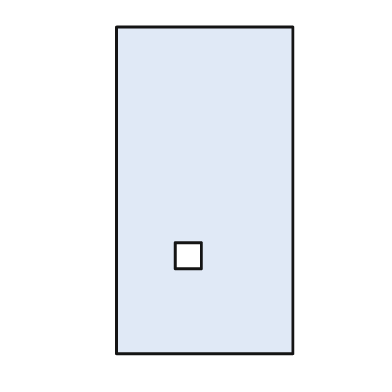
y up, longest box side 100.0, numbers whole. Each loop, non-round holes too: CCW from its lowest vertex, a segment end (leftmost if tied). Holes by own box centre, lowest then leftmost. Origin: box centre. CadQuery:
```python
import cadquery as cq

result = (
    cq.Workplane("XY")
    .moveTo(-27.0, -50.0)
    .lineTo(27.0, -50.0)
    .lineTo(27.0, 50.0)
    .lineTo(-27.0, 50.0)
    .close()
    .moveTo(-9.0, -24.0)
    .lineTo(-1.0, -24.0)
    .lineTo(-1.0, -16.0)
    .lineTo(-9.0, -16.0)
    .close()
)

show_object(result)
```